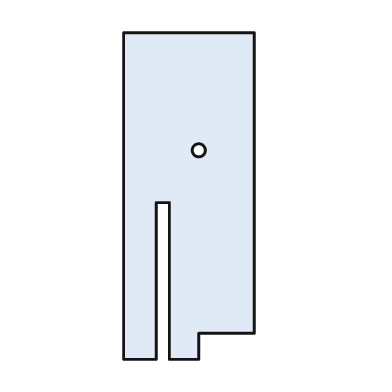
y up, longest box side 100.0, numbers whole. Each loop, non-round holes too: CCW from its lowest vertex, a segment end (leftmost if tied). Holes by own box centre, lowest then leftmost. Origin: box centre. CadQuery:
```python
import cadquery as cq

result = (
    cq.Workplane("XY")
    .moveTo(-20.0, -50.0)
    .lineTo(-10.0, -50.0)
    .lineTo(-10.0, -2.0)
    .lineTo(-6.0, -2.0)
    .lineTo(-6.0, -50.0)
    .lineTo(3.0, -50.0)
    .lineTo(3.0, -42.0)
    .lineTo(20.0, -42.0)
    .lineTo(20.0, 50.0)
    .lineTo(-20.0, 50.0)
    .close()
    .moveTo(3.0, 14.0)
    .circle(2.0)
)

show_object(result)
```